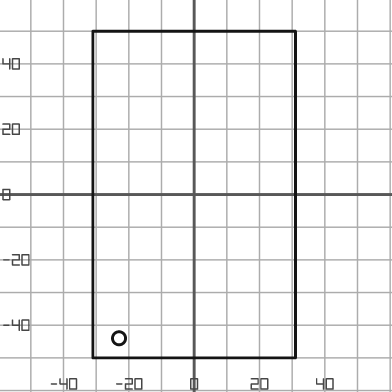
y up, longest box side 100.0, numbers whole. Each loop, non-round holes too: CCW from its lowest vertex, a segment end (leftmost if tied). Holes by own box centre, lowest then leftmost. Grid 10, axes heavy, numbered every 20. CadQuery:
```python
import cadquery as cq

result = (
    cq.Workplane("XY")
    .moveTo(-31.0, -50.0)
    .lineTo(31.0, -50.0)
    .lineTo(31.0, 50.0)
    .lineTo(-31.0, 50.0)
    .close()
    .moveTo(-23.0, -44.0)
    .circle(2.0)
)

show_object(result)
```